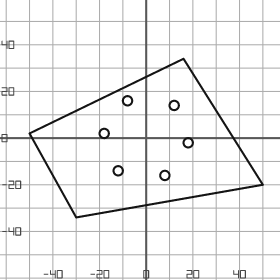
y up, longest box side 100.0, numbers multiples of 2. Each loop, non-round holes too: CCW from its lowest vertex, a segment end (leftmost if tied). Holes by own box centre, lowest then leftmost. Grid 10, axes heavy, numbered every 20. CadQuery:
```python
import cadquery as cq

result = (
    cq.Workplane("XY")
    .moveTo(-30.0, -34.0)
    .lineTo(50.0, -20.0)
    .lineTo(16.0, 34.0)
    .lineTo(-50.0, 2.0)
    .close()
    .moveTo(8.0, -16.0)
    .circle(2.0)
    .moveTo(-12.0, -14.0)
    .circle(2.0)
    .moveTo(18.0, -2.0)
    .circle(2.0)
    .moveTo(-18.0, 2.0)
    .circle(2.0)
    .moveTo(12.0, 14.0)
    .circle(2.0)
    .moveTo(-8.0, 16.0)
    .circle(2.0)
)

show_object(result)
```